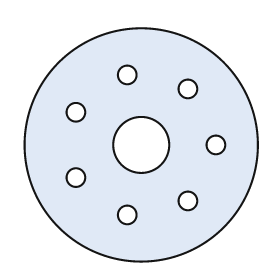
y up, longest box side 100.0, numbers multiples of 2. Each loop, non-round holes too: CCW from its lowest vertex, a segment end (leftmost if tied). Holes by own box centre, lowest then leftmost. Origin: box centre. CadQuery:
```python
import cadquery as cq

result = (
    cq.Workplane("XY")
    .moveTo(0.0, 0.0)
    .circle(50.0)
    .moveTo(-6.0, -30.0)
    .circle(4.0)
    .moveTo(20.0, -24.0)
    .circle(4.0)
    .moveTo(-28.0, -14.0)
    .circle(4.0)
    .moveTo(0.0, 0.0)
    .circle(12.0)
    .moveTo(32.0, 0.0)
    .circle(4.0)
    .moveTo(-28.0, 14.0)
    .circle(4.0)
    .moveTo(20.0, 24.0)
    .circle(4.0)
    .moveTo(-6.0, 30.0)
    .circle(4.0)
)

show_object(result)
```